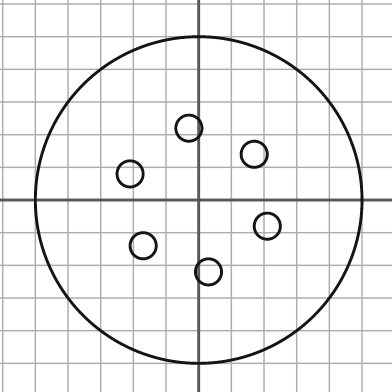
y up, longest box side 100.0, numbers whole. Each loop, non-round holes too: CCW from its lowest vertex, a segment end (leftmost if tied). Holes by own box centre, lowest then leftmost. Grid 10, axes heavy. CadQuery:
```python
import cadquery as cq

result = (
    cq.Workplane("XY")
    .moveTo(0.0, 0.0)
    .circle(50.0)
    .moveTo(3.0, -22.0)
    .circle(4.0)
    .moveTo(-17.0, -14.0)
    .circle(4.0)
    .moveTo(21.0, -8.0)
    .circle(4.0)
    .moveTo(-21.0, 8.0)
    .circle(4.0)
    .moveTo(17.0, 14.0)
    .circle(4.0)
    .moveTo(-3.0, 22.0)
    .circle(4.0)
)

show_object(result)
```